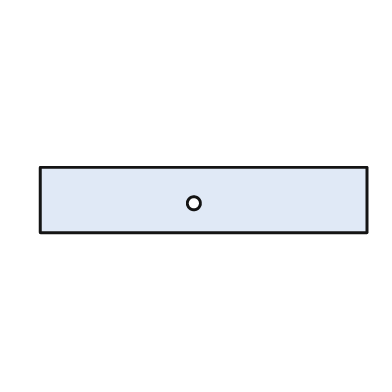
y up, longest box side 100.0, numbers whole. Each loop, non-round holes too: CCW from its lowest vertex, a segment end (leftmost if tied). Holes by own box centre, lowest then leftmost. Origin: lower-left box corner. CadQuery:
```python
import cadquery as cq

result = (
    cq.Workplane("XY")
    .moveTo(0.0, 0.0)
    .lineTo(100.0, 0.0)
    .lineTo(100.0, 20.0)
    .lineTo(0.0, 20.0)
    .close()
    .moveTo(47.0, 9.0)
    .circle(2.0)
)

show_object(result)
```